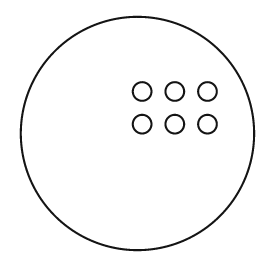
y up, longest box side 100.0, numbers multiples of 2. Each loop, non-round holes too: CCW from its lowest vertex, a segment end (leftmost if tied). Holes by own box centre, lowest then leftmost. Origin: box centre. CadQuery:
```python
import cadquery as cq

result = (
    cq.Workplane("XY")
    .moveTo(0.0, 0.0)
    .circle(50.0)
    .moveTo(2.0, 4.0)
    .circle(4.0)
    .moveTo(16.0, 4.0)
    .circle(4.0)
    .moveTo(30.0, 4.0)
    .circle(4.0)
    .moveTo(2.0, 18.0)
    .circle(4.0)
    .moveTo(16.0, 18.0)
    .circle(4.0)
    .moveTo(30.0, 18.0)
    .circle(4.0)
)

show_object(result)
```